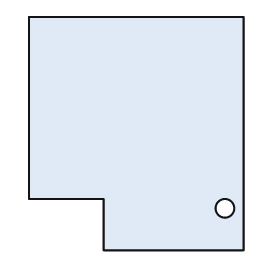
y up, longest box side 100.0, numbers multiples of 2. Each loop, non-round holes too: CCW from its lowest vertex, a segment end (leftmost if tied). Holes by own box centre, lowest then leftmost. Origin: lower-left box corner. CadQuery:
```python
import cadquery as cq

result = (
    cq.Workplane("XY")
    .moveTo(32.0, 0.0)
    .lineTo(92.0, 0.0)
    .lineTo(92.0, 100.0)
    .lineTo(0.0, 100.0)
    .lineTo(0.0, 22.0)
    .lineTo(32.0, 22.0)
    .close()
    .moveTo(84.0, 18.0)
    .circle(4.0)
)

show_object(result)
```